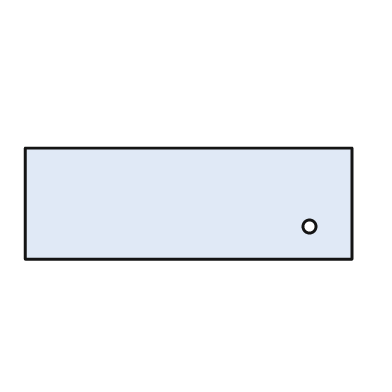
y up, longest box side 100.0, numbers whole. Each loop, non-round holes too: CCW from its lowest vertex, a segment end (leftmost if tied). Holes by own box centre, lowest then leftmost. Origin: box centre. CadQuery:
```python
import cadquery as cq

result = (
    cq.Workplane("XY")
    .moveTo(-50.0, -17.0)
    .lineTo(50.0, -17.0)
    .lineTo(50.0, 17.0)
    .lineTo(-50.0, 17.0)
    .close()
    .moveTo(37.0, -7.0)
    .circle(2.0)
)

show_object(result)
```